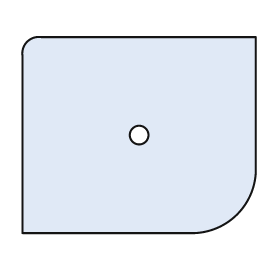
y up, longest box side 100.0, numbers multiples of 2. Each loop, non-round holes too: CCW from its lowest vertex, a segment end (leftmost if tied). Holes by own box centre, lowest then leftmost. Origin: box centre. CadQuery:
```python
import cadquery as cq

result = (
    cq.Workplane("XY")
    .moveTo(-50.0, -42.0)
    .lineTo(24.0, -42.0)
    .threePointArc((42.0, -34.0), (50.0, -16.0))
    .lineTo(50.0, 42.0)
    .lineTo(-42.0, 42.0)
    .threePointArc((-48.0, 40.0), (-50.0, 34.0))
    .close()
    .moveTo(0.0, 0.0)
    .circle(4.0)
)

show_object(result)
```